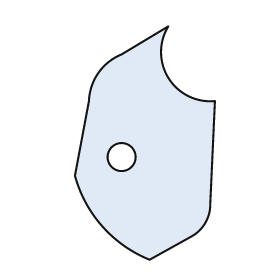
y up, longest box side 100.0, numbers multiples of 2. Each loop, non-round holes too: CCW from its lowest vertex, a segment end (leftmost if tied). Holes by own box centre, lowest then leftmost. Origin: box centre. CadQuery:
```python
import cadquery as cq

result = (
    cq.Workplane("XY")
    .moveTo(2.0, -50.0)
    .lineTo(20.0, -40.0)
    .threePointArc((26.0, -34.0), (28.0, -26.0))
    .lineTo(30.0, 18.0)
    .threePointArc((10.0, 28.0), (10.0, 50.0))
    .lineTo(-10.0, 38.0)
    .threePointArc((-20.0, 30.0), (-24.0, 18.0))
    .lineTo(-30.0, -14.0)
    .threePointArc((-18.0, -36.0), (2.0, -50.0))
    .close()
    .moveTo(-10.0, -6.0)
    .circle(6.0)
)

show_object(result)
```